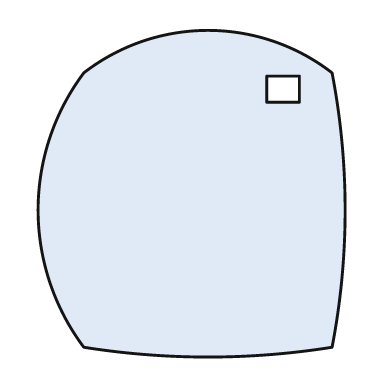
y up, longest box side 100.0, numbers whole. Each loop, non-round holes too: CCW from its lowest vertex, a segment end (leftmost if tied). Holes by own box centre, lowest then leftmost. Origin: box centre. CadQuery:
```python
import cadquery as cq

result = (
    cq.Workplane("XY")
    .moveTo(-33.0, -47.0)
    .threePointArc((5.0, -50.0), (43.0, -47.0))
    .threePointArc((47.0, -5.0), (43.0, 37.0))
    .threePointArc((5.0, 50.0), (-33.0, 37.0))
    .threePointArc((-47.0, -5.0), (-33.0, -47.0))
    .close()
    .moveTo(23.0, 28.0)
    .lineTo(33.0, 28.0)
    .lineTo(33.0, 36.0)
    .lineTo(23.0, 36.0)
    .close()
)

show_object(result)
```